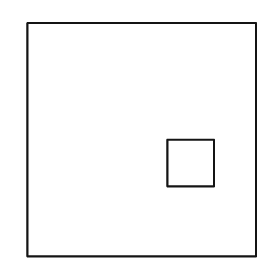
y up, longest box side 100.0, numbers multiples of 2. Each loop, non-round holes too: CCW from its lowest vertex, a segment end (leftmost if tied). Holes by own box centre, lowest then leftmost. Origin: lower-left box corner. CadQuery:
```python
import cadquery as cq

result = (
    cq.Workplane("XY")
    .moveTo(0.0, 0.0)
    .lineTo(98.0, 0.0)
    .lineTo(98.0, 100.0)
    .lineTo(0.0, 100.0)
    .close()
    .moveTo(60.0, 30.0)
    .lineTo(80.0, 30.0)
    .lineTo(80.0, 50.0)
    .lineTo(60.0, 50.0)
    .close()
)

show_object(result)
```